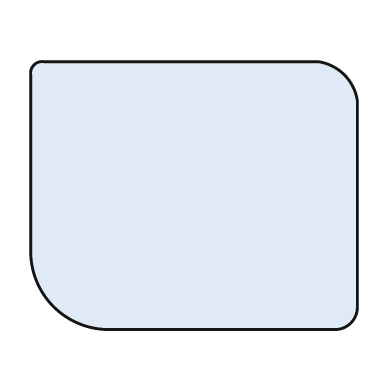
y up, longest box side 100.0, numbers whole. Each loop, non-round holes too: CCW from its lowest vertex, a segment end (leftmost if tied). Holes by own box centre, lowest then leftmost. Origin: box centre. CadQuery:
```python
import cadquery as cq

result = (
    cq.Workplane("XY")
    .moveTo(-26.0, -41.0)
    .lineTo(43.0, -41.0)
    .threePointArc((48.0, -39.0), (50.0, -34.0))
    .lineTo(50.0, 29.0)
    .threePointArc((46.0, 37.0), (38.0, 41.0))
    .lineTo(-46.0, 41.0)
    .threePointArc((-49.0, 40.0), (-50.0, 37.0))
    .lineTo(-50.0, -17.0)
    .threePointArc((-43.0, -34.0), (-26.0, -41.0))
    .close()
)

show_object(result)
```